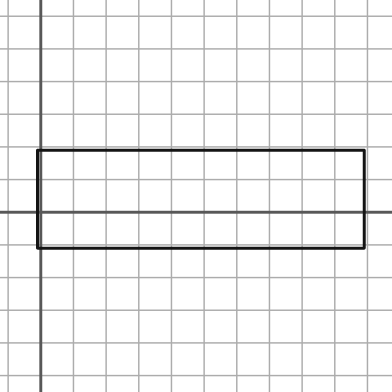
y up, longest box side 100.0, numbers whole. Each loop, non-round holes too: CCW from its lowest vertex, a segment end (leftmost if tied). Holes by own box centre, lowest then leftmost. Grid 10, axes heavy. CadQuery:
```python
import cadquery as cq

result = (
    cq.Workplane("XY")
    .moveTo(-1.0, -11.0)
    .lineTo(99.0, -11.0)
    .lineTo(99.0, 19.0)
    .lineTo(-1.0, 19.0)
    .close()
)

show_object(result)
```